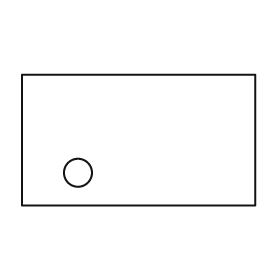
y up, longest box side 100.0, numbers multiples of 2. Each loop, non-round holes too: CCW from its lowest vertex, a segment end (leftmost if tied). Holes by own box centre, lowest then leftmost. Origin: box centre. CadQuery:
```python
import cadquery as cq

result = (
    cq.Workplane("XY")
    .moveTo(-50.0, -28.0)
    .lineTo(50.0, -28.0)
    .lineTo(50.0, 28.0)
    .lineTo(-50.0, 28.0)
    .close()
    .moveTo(-26.0, -14.0)
    .circle(6.0)
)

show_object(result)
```